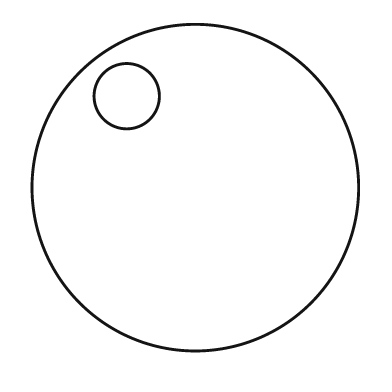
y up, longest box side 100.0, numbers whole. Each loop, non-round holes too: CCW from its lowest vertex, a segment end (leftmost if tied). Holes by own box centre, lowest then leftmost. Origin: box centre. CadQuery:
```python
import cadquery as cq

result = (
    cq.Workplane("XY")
    .moveTo(0.0, 0.0)
    .circle(50.0)
    .moveTo(-21.0, 28.0)
    .circle(10.0)
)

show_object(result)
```